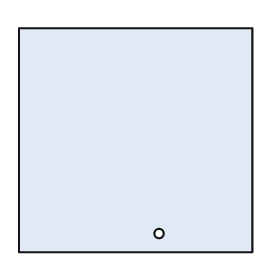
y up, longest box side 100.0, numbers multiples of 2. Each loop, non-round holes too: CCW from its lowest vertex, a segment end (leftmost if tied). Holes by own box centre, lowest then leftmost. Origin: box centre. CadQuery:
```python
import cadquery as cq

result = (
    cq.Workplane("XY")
    .moveTo(-50.0, -48.0)
    .lineTo(50.0, -48.0)
    .lineTo(50.0, 48.0)
    .lineTo(-50.0, 48.0)
    .close()
    .moveTo(10.0, -40.0)
    .circle(2.0)
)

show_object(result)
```